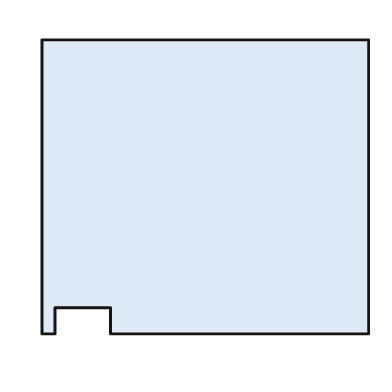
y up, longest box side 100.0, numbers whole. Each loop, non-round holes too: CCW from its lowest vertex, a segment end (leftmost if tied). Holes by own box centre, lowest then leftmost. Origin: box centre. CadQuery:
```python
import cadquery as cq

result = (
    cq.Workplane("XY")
    .moveTo(-50.0, -45.0)
    .lineTo(-46.0, -45.0)
    .lineTo(-46.0, -37.0)
    .lineTo(-29.0, -37.0)
    .lineTo(-29.0, -45.0)
    .lineTo(50.0, -45.0)
    .lineTo(50.0, 45.0)
    .lineTo(-50.0, 45.0)
    .close()
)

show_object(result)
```